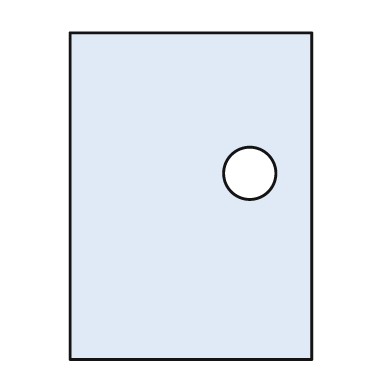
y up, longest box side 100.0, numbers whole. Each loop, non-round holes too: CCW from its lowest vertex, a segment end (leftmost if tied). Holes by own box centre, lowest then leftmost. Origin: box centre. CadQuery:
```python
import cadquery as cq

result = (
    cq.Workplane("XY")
    .moveTo(-37.0, -50.0)
    .lineTo(37.0, -50.0)
    .lineTo(37.0, 50.0)
    .lineTo(-37.0, 50.0)
    .close()
    .moveTo(18.0, 7.0)
    .circle(8.0)
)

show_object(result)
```